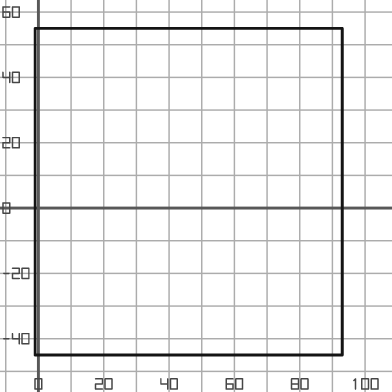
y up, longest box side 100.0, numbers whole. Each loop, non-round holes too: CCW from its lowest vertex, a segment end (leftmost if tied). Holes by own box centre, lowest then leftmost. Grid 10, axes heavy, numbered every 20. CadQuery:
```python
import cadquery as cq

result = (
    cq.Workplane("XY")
    .moveTo(-1.0, -45.0)
    .lineTo(93.0, -45.0)
    .lineTo(93.0, 55.0)
    .lineTo(-1.0, 55.0)
    .close()
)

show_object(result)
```